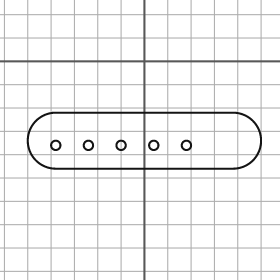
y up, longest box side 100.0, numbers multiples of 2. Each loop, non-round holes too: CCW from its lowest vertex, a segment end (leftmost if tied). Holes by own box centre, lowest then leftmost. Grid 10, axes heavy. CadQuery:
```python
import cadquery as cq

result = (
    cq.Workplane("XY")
    .moveTo(-38.0, -46.0)
    .lineTo(38.0, -46.0)
    .threePointArc((50.0, -34.0), (38.0, -22.0))
    .lineTo(-38.0, -22.0)
    .threePointArc((-50.0, -34.0), (-38.0, -46.0))
    .close()
    .moveTo(-38.0, -36.0)
    .circle(2.0)
    .moveTo(-24.0, -36.0)
    .circle(2.0)
    .moveTo(-10.0, -36.0)
    .circle(2.0)
    .moveTo(4.0, -36.0)
    .circle(2.0)
    .moveTo(18.0, -36.0)
    .circle(2.0)
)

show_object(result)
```